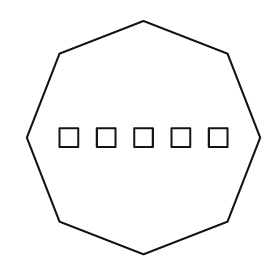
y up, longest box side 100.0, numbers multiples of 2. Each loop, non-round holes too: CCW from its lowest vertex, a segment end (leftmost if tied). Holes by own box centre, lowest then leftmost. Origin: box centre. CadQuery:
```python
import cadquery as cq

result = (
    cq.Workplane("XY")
    .moveTo(0.0, -50.0)
    .lineTo(36.0, -36.0)
    .lineTo(50.0, 0.0)
    .lineTo(36.0, 36.0)
    .lineTo(0.0, 50.0)
    .lineTo(-36.0, 36.0)
    .lineTo(-50.0, 0.0)
    .lineTo(-36.0, -36.0)
    .close()
    .moveTo(-36.0, -4.0)
    .lineTo(-28.0, -4.0)
    .lineTo(-28.0, 4.0)
    .lineTo(-36.0, 4.0)
    .close()
    .moveTo(-20.0, -4.0)
    .lineTo(-12.0, -4.0)
    .lineTo(-12.0, 4.0)
    .lineTo(-20.0, 4.0)
    .close()
    .moveTo(-4.0, -4.0)
    .lineTo(4.0, -4.0)
    .lineTo(4.0, 4.0)
    .lineTo(-4.0, 4.0)
    .close()
    .moveTo(12.0, -4.0)
    .lineTo(20.0, -4.0)
    .lineTo(20.0, 4.0)
    .lineTo(12.0, 4.0)
    .close()
    .moveTo(28.0, -4.0)
    .lineTo(36.0, -4.0)
    .lineTo(36.0, 4.0)
    .lineTo(28.0, 4.0)
    .close()
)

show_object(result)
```